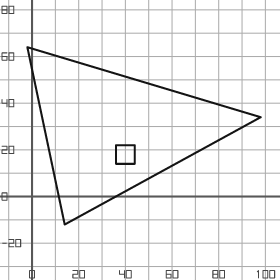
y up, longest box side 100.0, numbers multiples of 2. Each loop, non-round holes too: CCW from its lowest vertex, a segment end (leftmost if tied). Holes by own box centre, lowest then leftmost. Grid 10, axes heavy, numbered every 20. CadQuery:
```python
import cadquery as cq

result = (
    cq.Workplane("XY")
    .moveTo(14.0, -12.0)
    .lineTo(98.0, 34.0)
    .lineTo(-2.0, 64.0)
    .close()
    .moveTo(36.0, 14.0)
    .lineTo(44.0, 14.0)
    .lineTo(44.0, 22.0)
    .lineTo(36.0, 22.0)
    .close()
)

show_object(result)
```